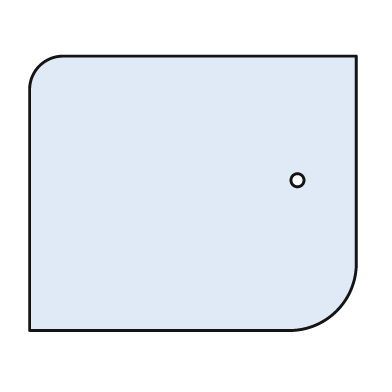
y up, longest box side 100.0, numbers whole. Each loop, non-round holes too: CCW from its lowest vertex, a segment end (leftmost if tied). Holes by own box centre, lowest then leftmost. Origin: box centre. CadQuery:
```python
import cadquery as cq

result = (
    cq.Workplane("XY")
    .moveTo(-50.0, -42.0)
    .lineTo(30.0, -42.0)
    .threePointArc((44.0, -36.0), (50.0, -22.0))
    .lineTo(50.0, 42.0)
    .lineTo(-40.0, 42.0)
    .threePointArc((-47.0, 39.0), (-50.0, 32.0))
    .close()
    .moveTo(32.0, 4.0)
    .circle(2.0)
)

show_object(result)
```